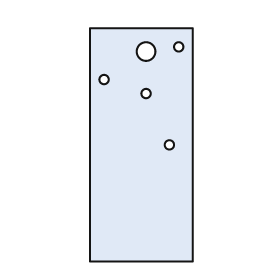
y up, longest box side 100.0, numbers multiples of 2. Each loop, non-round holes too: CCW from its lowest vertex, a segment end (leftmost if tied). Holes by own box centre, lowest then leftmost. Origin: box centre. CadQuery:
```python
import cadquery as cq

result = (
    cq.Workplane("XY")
    .moveTo(-22.0, -50.0)
    .lineTo(22.0, -50.0)
    .lineTo(22.0, 50.0)
    .lineTo(-22.0, 50.0)
    .close()
    .moveTo(12.0, 0.0)
    .circle(2.0)
    .moveTo(2.0, 22.0)
    .circle(2.0)
    .moveTo(-16.0, 28.0)
    .circle(2.0)
    .moveTo(2.0, 40.0)
    .circle(4.0)
    .moveTo(16.0, 42.0)
    .circle(2.0)
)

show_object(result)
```